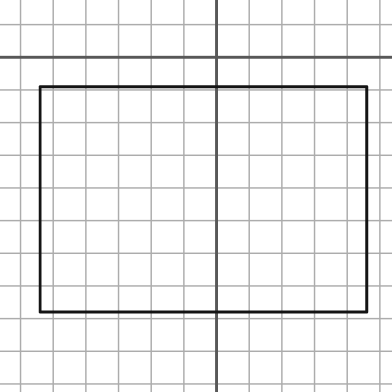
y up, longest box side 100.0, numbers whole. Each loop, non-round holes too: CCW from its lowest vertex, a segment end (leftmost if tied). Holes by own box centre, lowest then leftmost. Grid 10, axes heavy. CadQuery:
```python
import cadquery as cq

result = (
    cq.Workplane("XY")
    .moveTo(-54.0, -78.0)
    .lineTo(46.0, -78.0)
    .lineTo(46.0, -9.0)
    .lineTo(-54.0, -9.0)
    .close()
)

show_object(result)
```